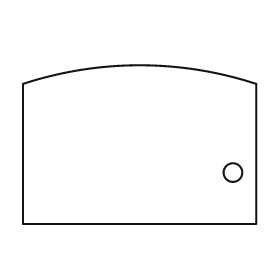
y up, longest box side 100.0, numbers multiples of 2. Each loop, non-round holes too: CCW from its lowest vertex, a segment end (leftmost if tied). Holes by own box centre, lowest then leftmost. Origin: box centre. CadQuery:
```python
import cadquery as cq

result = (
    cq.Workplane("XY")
    .moveTo(-50.0, -34.0)
    .lineTo(50.0, -34.0)
    .lineTo(50.0, 26.0)
    .threePointArc((0.0, 34.0), (-50.0, 26.0))
    .close()
    .moveTo(40.0, -12.0)
    .circle(4.0)
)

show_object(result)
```